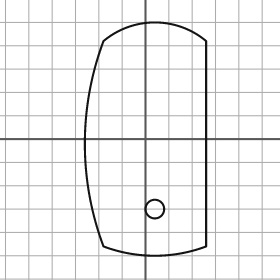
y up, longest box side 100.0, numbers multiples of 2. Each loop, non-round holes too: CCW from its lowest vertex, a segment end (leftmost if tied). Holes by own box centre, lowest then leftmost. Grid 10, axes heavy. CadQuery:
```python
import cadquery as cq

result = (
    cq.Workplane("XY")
    .moveTo(-18.0, -46.0)
    .threePointArc((4.0, -50.0), (26.0, -46.0))
    .lineTo(26.0, 42.0)
    .threePointArc((4.0, 50.0), (-18.0, 42.0))
    .threePointArc((-26.0, -2.0), (-18.0, -46.0))
    .close()
    .moveTo(4.0, -30.0)
    .circle(4.0)
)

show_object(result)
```